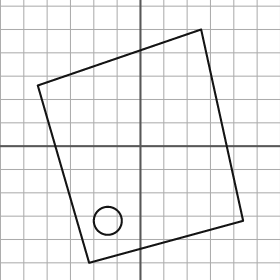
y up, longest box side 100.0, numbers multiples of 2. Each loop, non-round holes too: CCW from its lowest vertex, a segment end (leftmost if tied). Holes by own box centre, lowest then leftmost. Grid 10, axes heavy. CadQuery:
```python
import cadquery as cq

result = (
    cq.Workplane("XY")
    .moveTo(-22.0, -50.0)
    .lineTo(44.0, -32.0)
    .lineTo(26.0, 50.0)
    .lineTo(-44.0, 26.0)
    .close()
    .moveTo(-14.0, -32.0)
    .circle(6.0)
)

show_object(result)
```